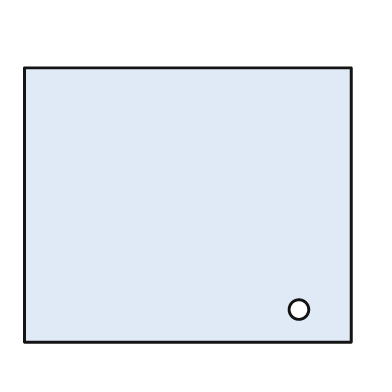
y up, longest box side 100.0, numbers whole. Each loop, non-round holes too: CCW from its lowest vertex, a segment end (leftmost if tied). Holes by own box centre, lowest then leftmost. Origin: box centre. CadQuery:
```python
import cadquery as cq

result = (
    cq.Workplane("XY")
    .moveTo(-50.0, -42.0)
    .lineTo(50.0, -42.0)
    .lineTo(50.0, 42.0)
    .lineTo(-50.0, 42.0)
    .close()
    .moveTo(34.0, -32.0)
    .circle(3.0)
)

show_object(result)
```